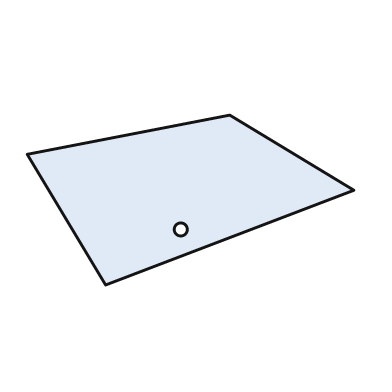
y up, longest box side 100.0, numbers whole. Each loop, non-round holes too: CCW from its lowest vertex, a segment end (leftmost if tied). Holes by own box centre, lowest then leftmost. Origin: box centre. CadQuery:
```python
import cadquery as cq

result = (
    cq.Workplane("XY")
    .moveTo(-26.0, -26.0)
    .lineTo(50.0, 3.0)
    .lineTo(12.0, 26.0)
    .lineTo(-50.0, 14.0)
    .close()
    .moveTo(-3.0, -9.0)
    .circle(2.0)
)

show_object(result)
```